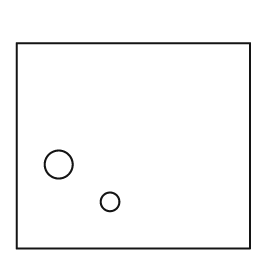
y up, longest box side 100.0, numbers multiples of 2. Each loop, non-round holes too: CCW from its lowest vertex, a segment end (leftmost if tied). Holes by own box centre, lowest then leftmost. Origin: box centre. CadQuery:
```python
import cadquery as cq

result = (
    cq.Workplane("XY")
    .moveTo(-50.0, -44.0)
    .lineTo(50.0, -44.0)
    .lineTo(50.0, 44.0)
    .lineTo(-50.0, 44.0)
    .close()
    .moveTo(-10.0, -24.0)
    .circle(4.0)
    .moveTo(-32.0, -8.0)
    .circle(6.0)
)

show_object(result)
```